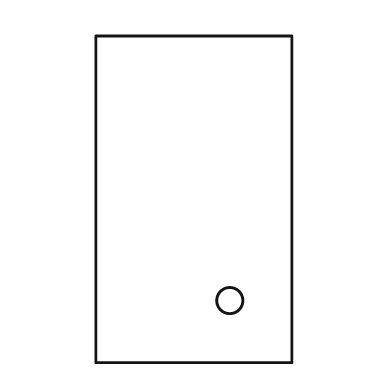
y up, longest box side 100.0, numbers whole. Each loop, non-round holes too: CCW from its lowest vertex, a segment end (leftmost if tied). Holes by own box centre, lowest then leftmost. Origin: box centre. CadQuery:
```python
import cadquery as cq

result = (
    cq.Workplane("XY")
    .moveTo(-30.0, -50.0)
    .lineTo(30.0, -50.0)
    .lineTo(30.0, 50.0)
    .lineTo(-30.0, 50.0)
    .close()
    .moveTo(11.0, -31.0)
    .circle(4.0)
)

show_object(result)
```